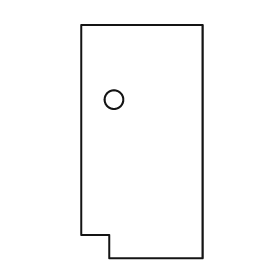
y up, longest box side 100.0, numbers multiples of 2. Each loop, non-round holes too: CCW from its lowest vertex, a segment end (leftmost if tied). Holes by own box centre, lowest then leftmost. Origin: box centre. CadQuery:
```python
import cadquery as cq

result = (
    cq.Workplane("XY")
    .moveTo(-14.0, -50.0)
    .lineTo(26.0, -50.0)
    .lineTo(26.0, 50.0)
    .lineTo(-26.0, 50.0)
    .lineTo(-26.0, -40.0)
    .lineTo(-14.0, -40.0)
    .close()
    .moveTo(-12.0, 18.0)
    .circle(4.0)
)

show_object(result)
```